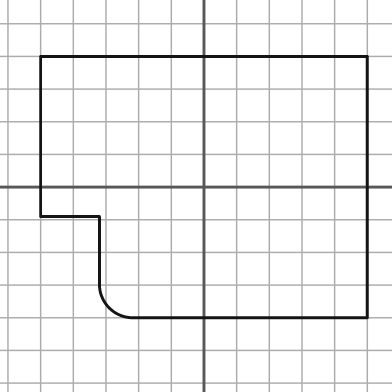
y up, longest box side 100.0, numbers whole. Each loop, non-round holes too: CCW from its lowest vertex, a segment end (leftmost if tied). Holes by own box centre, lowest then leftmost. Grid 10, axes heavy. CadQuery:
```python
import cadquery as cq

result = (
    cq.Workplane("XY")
    .moveTo(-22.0, -40.0)
    .lineTo(50.0, -40.0)
    .lineTo(50.0, 40.0)
    .lineTo(-50.0, 40.0)
    .lineTo(-50.0, -9.0)
    .lineTo(-32.0, -9.0)
    .lineTo(-32.0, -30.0)
    .threePointArc((-29.0, -37.0), (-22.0, -40.0))
    .close()
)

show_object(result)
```